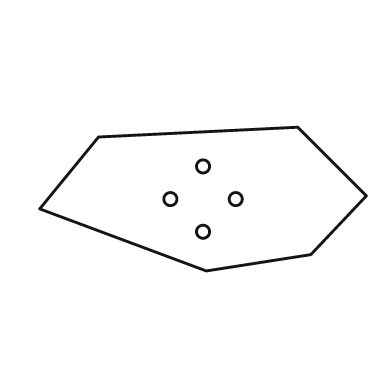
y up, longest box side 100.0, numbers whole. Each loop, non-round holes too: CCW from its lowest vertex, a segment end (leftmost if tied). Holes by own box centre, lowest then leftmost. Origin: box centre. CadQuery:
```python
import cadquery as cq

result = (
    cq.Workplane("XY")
    .moveTo(1.0, -22.0)
    .lineTo(33.0, -17.0)
    .lineTo(50.0, 1.0)
    .lineTo(29.0, 22.0)
    .lineTo(-32.0, 19.0)
    .lineTo(-50.0, -3.0)
    .close()
    .moveTo(0.0, -10.0)
    .circle(2.0)
    .moveTo(-10.0, 0.0)
    .circle(2.0)
    .moveTo(10.0, 0.0)
    .circle(2.0)
    .moveTo(0.0, 10.0)
    .circle(2.0)
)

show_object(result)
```